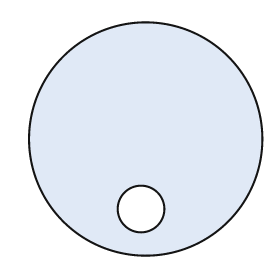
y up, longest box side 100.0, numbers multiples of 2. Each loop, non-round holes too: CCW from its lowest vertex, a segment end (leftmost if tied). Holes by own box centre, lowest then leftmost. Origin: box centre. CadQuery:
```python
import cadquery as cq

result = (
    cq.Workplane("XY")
    .moveTo(0.0, 0.0)
    .circle(50.0)
    .moveTo(-2.0, -30.0)
    .circle(10.0)
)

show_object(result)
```